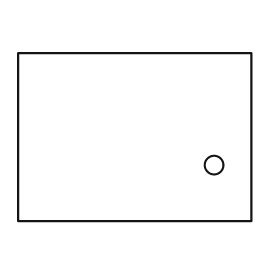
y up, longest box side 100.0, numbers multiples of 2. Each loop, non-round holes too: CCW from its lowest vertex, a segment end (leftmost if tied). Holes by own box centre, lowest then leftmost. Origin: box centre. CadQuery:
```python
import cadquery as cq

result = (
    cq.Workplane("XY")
    .moveTo(-50.0, -36.0)
    .lineTo(50.0, -36.0)
    .lineTo(50.0, 36.0)
    .lineTo(-50.0, 36.0)
    .close()
    .moveTo(34.0, -12.0)
    .circle(4.0)
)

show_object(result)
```